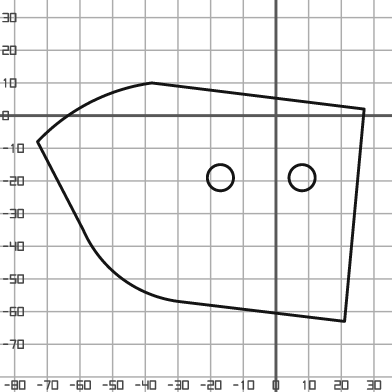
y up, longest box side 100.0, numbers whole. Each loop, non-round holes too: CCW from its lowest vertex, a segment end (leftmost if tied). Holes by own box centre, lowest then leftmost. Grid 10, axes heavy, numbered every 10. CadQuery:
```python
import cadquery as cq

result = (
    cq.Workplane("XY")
    .moveTo(21.0, -63.0)
    .lineTo(27.0, 2.0)
    .lineTo(-38.0, 10.0)
    .threePointArc((-57.0, 4.0), (-73.0, -8.0))
    .lineTo(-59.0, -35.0)
    .threePointArc((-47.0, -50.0), (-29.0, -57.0))
    .close()
    .moveTo(-17.0, -19.0)
    .circle(4.0)
    .moveTo(8.0, -19.0)
    .circle(4.0)
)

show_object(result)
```